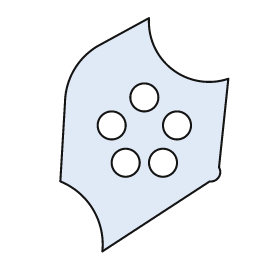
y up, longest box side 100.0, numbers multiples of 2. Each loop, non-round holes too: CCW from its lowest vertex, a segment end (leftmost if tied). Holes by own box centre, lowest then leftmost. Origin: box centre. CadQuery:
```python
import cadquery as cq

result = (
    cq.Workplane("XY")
    .moveTo(-18.0, -50.0)
    .lineTo(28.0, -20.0)
    .threePointArc((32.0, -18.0), (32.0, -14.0))
    .lineTo(36.0, 24.0)
    .threePointArc((12.0, 28.0), (2.0, 50.0))
    .lineTo(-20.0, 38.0)
    .threePointArc((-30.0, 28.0), (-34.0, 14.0))
    .lineTo(-36.0, -20.0)
    .threePointArc((-22.0, -32.0), (-18.0, -50.0))
    .close()
    .moveTo(-8.0, -12.0)
    .circle(6.0)
    .moveTo(8.0, -12.0)
    .circle(6.0)
    .moveTo(-14.0, 4.0)
    .circle(6.0)
    .moveTo(14.0, 4.0)
    .circle(6.0)
    .moveTo(0.0, 16.0)
    .circle(6.0)
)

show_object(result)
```